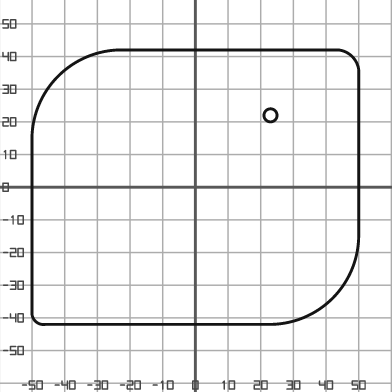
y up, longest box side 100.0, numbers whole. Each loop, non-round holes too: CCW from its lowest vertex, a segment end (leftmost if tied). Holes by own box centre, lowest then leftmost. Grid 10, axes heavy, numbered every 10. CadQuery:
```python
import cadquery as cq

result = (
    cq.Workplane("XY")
    .moveTo(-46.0, -42.0)
    .lineTo(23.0, -42.0)
    .threePointArc((42.0, -34.0), (50.0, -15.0))
    .lineTo(50.0, 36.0)
    .threePointArc((48.0, 40.0), (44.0, 42.0))
    .lineTo(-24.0, 42.0)
    .threePointArc((-42.0, 34.0), (-50.0, 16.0))
    .lineTo(-50.0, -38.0)
    .threePointArc((-49.0, -41.0), (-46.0, -42.0))
    .close()
    .moveTo(23.0, 22.0)
    .circle(2.0)
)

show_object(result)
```